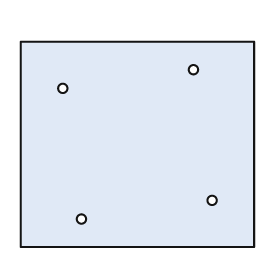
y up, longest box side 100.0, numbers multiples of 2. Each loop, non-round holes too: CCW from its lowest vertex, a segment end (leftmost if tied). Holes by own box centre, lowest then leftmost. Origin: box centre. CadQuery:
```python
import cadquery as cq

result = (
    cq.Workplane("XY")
    .moveTo(-50.0, -44.0)
    .lineTo(50.0, -44.0)
    .lineTo(50.0, 44.0)
    .lineTo(-50.0, 44.0)
    .close()
    .moveTo(-24.0, -32.0)
    .circle(2.0)
    .moveTo(32.0, -24.0)
    .circle(2.0)
    .moveTo(-32.0, 24.0)
    .circle(2.0)
    .moveTo(24.0, 32.0)
    .circle(2.0)
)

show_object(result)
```